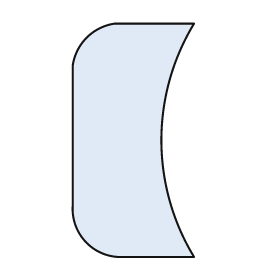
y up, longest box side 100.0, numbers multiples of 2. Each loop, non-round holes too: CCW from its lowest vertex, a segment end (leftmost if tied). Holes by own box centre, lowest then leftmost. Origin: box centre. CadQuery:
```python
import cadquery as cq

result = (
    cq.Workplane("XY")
    .moveTo(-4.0, -50.0)
    .lineTo(26.0, -50.0)
    .threePointArc((12.0, 0.0), (26.0, 50.0))
    .lineTo(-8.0, 50.0)
    .threePointArc((-20.0, 44.0), (-26.0, 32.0))
    .lineTo(-26.0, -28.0)
    .threePointArc((-20.0, -44.0), (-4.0, -50.0))
    .close()
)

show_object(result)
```